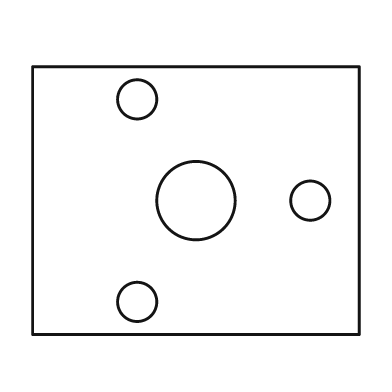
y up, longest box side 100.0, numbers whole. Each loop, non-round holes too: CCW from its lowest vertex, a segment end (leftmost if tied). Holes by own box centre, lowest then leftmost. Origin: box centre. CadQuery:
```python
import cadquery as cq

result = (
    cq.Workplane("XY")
    .moveTo(-50.0, -41.0)
    .lineTo(50.0, -41.0)
    .lineTo(50.0, 41.0)
    .lineTo(-50.0, 41.0)
    .close()
    .moveTo(-18.0, -31.0)
    .circle(6.0)
    .moveTo(0.0, 0.0)
    .circle(12.0)
    .moveTo(35.0, 0.0)
    .circle(6.0)
    .moveTo(-18.0, 31.0)
    .circle(6.0)
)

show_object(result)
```